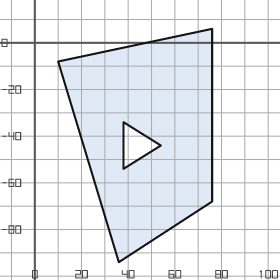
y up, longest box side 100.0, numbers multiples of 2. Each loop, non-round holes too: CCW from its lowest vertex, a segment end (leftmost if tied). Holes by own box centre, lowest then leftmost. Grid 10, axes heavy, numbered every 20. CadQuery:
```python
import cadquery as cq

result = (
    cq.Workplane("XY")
    .moveTo(36.0, -94.0)
    .lineTo(76.0, -68.0)
    .lineTo(76.0, 6.0)
    .lineTo(10.0, -8.0)
    .close()
    .moveTo(38.0, -54.0)
    .lineTo(54.0, -44.0)
    .lineTo(38.0, -34.0)
    .close()
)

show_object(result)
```